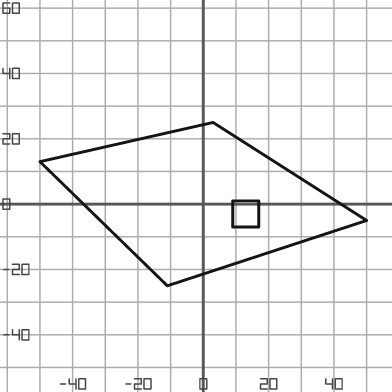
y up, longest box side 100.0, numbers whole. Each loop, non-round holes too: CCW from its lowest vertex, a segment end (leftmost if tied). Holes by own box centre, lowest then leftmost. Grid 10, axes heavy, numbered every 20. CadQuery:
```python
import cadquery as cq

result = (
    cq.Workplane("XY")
    .moveTo(-11.0, -25.0)
    .lineTo(50.0, -5.0)
    .lineTo(3.0, 25.0)
    .lineTo(-50.0, 13.0)
    .close()
    .moveTo(9.0, -7.0)
    .lineTo(17.0, -7.0)
    .lineTo(17.0, 1.0)
    .lineTo(9.0, 1.0)
    .close()
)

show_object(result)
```